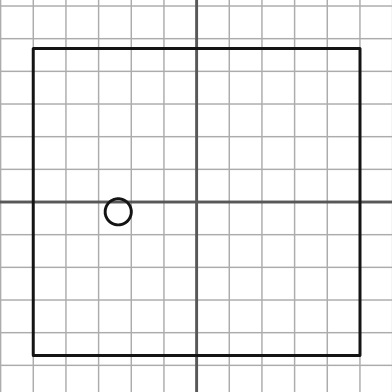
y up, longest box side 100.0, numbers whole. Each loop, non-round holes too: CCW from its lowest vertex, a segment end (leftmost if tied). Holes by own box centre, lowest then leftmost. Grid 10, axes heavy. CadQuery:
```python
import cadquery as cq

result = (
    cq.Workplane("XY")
    .moveTo(-50.0, -47.0)
    .lineTo(50.0, -47.0)
    .lineTo(50.0, 47.0)
    .lineTo(-50.0, 47.0)
    .close()
    .moveTo(-24.0, -3.0)
    .circle(4.0)
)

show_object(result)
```